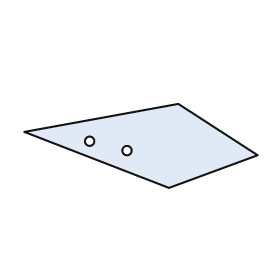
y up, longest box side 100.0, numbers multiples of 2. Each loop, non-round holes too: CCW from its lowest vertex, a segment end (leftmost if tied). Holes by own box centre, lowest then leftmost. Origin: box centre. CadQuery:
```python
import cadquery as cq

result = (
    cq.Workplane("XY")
    .moveTo(12.0, -18.0)
    .lineTo(50.0, -4.0)
    .lineTo(16.0, 18.0)
    .lineTo(-50.0, 6.0)
    .close()
    .moveTo(-6.0, -2.0)
    .circle(2.0)
    .moveTo(-22.0, 2.0)
    .circle(2.0)
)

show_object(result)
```